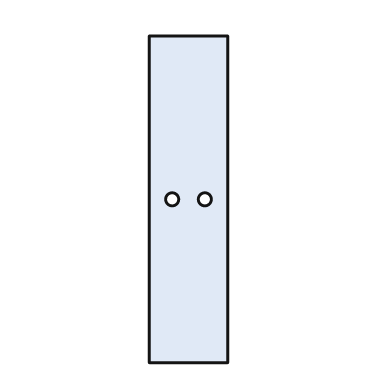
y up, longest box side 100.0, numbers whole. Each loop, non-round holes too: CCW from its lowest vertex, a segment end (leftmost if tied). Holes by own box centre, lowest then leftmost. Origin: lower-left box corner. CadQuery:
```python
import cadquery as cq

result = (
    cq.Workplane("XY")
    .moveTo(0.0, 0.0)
    .lineTo(24.0, 0.0)
    .lineTo(24.0, 100.0)
    .lineTo(0.0, 100.0)
    .close()
    .moveTo(7.0, 50.0)
    .circle(2.0)
    .moveTo(17.0, 50.0)
    .circle(2.0)
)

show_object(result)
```